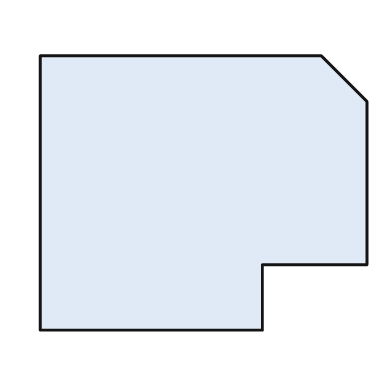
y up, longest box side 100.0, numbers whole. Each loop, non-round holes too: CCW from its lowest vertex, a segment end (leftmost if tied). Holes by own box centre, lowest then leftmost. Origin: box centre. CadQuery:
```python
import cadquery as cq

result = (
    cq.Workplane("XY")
    .moveTo(-50.0, -42.0)
    .lineTo(18.0, -42.0)
    .lineTo(18.0, -22.0)
    .lineTo(50.0, -22.0)
    .lineTo(50.0, 28.0)
    .lineTo(36.0, 42.0)
    .lineTo(-50.0, 42.0)
    .close()
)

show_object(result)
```